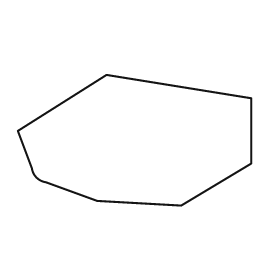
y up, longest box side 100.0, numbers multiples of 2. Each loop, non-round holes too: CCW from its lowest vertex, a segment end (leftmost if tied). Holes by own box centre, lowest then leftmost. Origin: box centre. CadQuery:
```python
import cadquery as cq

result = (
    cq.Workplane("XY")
    .moveTo(20.0, -28.0)
    .lineTo(50.0, -10.0)
    .lineTo(50.0, 18.0)
    .lineTo(-12.0, 28.0)
    .lineTo(-50.0, 4.0)
    .lineTo(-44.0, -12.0)
    .threePointArc((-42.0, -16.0), (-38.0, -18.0))
    .lineTo(-16.0, -26.0)
    .close()
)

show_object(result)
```